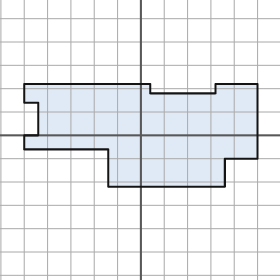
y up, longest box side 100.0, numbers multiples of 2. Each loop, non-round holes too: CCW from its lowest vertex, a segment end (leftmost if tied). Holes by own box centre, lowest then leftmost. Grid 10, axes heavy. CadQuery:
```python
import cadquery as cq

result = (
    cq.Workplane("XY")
    .moveTo(-14.0, -22.0)
    .lineTo(36.0, -22.0)
    .lineTo(36.0, -10.0)
    .lineTo(50.0, -10.0)
    .lineTo(50.0, 22.0)
    .lineTo(32.0, 22.0)
    .lineTo(32.0, 18.0)
    .lineTo(4.0, 18.0)
    .lineTo(4.0, 22.0)
    .lineTo(-50.0, 22.0)
    .lineTo(-50.0, 14.0)
    .lineTo(-44.0, 14.0)
    .lineTo(-44.0, 0.0)
    .lineTo(-50.0, 0.0)
    .lineTo(-50.0, -6.0)
    .lineTo(-14.0, -6.0)
    .close()
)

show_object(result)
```